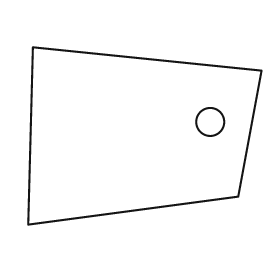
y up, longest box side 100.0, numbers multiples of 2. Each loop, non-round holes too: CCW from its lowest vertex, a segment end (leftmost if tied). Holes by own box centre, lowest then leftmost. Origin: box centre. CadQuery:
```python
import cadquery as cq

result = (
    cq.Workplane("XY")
    .moveTo(-50.0, -38.0)
    .lineTo(40.0, -26.0)
    .lineTo(50.0, 28.0)
    .lineTo(-48.0, 38.0)
    .close()
    .moveTo(28.0, 6.0)
    .circle(6.0)
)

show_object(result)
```